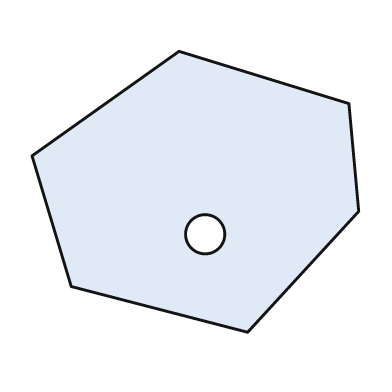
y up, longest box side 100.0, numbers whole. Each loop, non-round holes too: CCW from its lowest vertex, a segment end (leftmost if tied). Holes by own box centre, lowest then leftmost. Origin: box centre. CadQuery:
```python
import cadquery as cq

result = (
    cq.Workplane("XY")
    .moveTo(16.0, -43.0)
    .lineTo(50.0, -6.0)
    .lineTo(47.0, 27.0)
    .lineTo(-5.0, 43.0)
    .lineTo(-50.0, 11.0)
    .lineTo(-38.0, -29.0)
    .close()
    .moveTo(3.0, -13.0)
    .circle(6.0)
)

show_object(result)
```